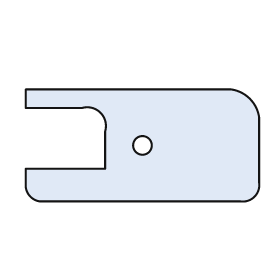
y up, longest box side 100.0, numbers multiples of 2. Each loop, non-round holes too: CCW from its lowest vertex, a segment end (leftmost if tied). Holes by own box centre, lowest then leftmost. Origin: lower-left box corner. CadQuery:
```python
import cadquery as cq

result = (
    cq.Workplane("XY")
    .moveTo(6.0, 0.0)
    .lineTo(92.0, 0.0)
    .threePointArc((98.0, 2.0), (100.0, 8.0))
    .lineTo(100.0, 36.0)
    .threePointArc((96.0, 44.0), (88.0, 48.0))
    .lineTo(0.0, 48.0)
    .lineTo(0.0, 40.0)
    .lineTo(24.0, 40.0)
    .threePointArc((32.0, 38.0), (34.0, 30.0))
    .lineTo(34.0, 14.0)
    .lineTo(0.0, 14.0)
    .lineTo(0.0, 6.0)
    .threePointArc((2.0, 2.0), (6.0, 0.0))
    .close()
    .moveTo(50.0, 24.0)
    .circle(4.0)
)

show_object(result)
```